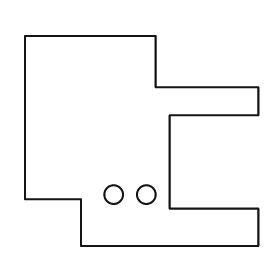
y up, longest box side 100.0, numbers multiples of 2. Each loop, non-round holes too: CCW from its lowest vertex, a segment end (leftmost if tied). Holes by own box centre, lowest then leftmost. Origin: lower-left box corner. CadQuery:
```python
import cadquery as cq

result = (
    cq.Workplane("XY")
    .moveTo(24.0, 0.0)
    .lineTo(100.0, 0.0)
    .lineTo(100.0, 16.0)
    .lineTo(62.0, 16.0)
    .lineTo(62.0, 56.0)
    .lineTo(100.0, 56.0)
    .lineTo(100.0, 68.0)
    .lineTo(56.0, 68.0)
    .lineTo(56.0, 90.0)
    .lineTo(0.0, 90.0)
    .lineTo(0.0, 20.0)
    .lineTo(24.0, 20.0)
    .close()
    .moveTo(38.0, 22.0)
    .circle(4.0)
    .moveTo(52.0, 22.0)
    .circle(4.0)
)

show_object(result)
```